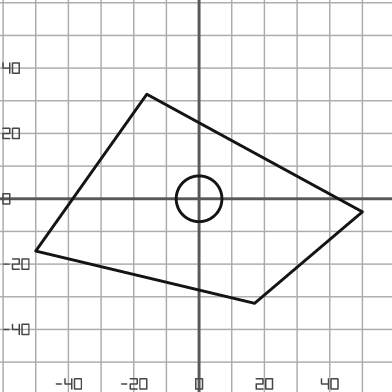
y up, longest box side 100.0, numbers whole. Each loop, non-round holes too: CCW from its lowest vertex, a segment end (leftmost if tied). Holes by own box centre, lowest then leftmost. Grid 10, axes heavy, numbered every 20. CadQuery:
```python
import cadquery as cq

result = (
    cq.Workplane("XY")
    .moveTo(17.0, -32.0)
    .lineTo(50.0, -4.0)
    .lineTo(-16.0, 32.0)
    .lineTo(-50.0, -16.0)
    .close()
    .moveTo(0.0, 0.0)
    .circle(7.0)
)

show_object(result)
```